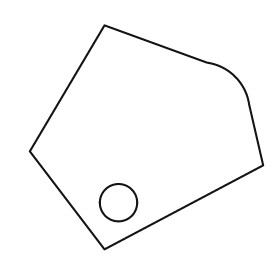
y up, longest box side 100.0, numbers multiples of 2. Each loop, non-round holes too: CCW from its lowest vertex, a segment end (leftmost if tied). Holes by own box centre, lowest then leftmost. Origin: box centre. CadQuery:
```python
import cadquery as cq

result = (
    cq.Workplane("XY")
    .moveTo(-18.0, -48.0)
    .lineTo(50.0, -12.0)
    .lineTo(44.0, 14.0)
    .threePointArc((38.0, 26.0), (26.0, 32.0))
    .lineTo(-18.0, 48.0)
    .lineTo(-50.0, -6.0)
    .close()
    .moveTo(-12.0, -28.0)
    .circle(8.0)
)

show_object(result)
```